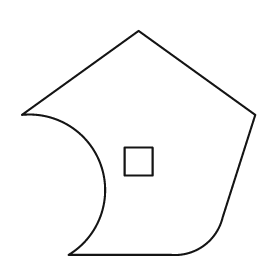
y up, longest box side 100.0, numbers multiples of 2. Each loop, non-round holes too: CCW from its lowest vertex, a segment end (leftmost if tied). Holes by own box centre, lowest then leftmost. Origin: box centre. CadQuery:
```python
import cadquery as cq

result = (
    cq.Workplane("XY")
    .moveTo(-30.0, -48.0)
    .lineTo(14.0, -48.0)
    .threePointArc((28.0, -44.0), (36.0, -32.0))
    .lineTo(50.0, 12.0)
    .lineTo(0.0, 48.0)
    .lineTo(-50.0, 12.0)
    .threePointArc((-16.0, -10.0), (-30.0, -48.0))
    .close()
    .moveTo(-6.0, -14.0)
    .lineTo(6.0, -14.0)
    .lineTo(6.0, -2.0)
    .lineTo(-6.0, -2.0)
    .close()
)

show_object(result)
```